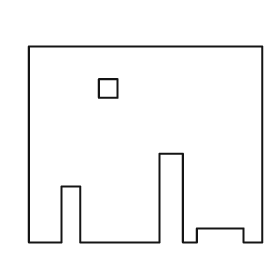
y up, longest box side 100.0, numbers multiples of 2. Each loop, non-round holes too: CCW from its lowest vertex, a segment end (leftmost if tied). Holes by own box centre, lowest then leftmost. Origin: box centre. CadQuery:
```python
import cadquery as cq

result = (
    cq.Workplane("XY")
    .moveTo(-50.0, -42.0)
    .lineTo(-36.0, -42.0)
    .lineTo(-36.0, -18.0)
    .lineTo(-28.0, -18.0)
    .lineTo(-28.0, -42.0)
    .lineTo(6.0, -42.0)
    .lineTo(6.0, -4.0)
    .lineTo(16.0, -4.0)
    .lineTo(16.0, -42.0)
    .lineTo(22.0, -42.0)
    .lineTo(22.0, -36.0)
    .lineTo(42.0, -36.0)
    .lineTo(42.0, -42.0)
    .lineTo(50.0, -42.0)
    .lineTo(50.0, 42.0)
    .lineTo(-50.0, 42.0)
    .close()
    .moveTo(-20.0, 20.0)
    .lineTo(-12.0, 20.0)
    .lineTo(-12.0, 28.0)
    .lineTo(-20.0, 28.0)
    .close()
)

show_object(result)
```